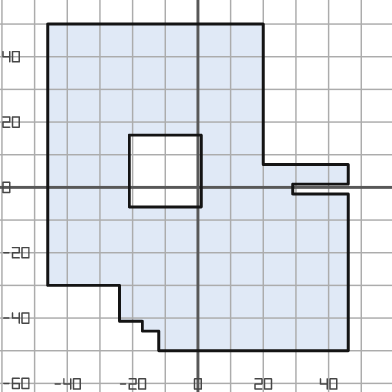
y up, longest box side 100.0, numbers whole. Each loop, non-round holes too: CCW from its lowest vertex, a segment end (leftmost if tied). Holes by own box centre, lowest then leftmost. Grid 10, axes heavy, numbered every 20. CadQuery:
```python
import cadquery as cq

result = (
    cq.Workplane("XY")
    .moveTo(-12.0, -50.0)
    .lineTo(46.0, -50.0)
    .lineTo(46.0, -2.0)
    .lineTo(29.0, -2.0)
    .lineTo(29.0, 1.0)
    .lineTo(46.0, 1.0)
    .lineTo(46.0, 7.0)
    .lineTo(20.0, 7.0)
    .lineTo(20.0, 50.0)
    .lineTo(-46.0, 50.0)
    .lineTo(-46.0, -30.0)
    .lineTo(-24.0, -30.0)
    .lineTo(-24.0, -41.0)
    .lineTo(-17.0, -41.0)
    .lineTo(-17.0, -44.0)
    .lineTo(-12.0, -44.0)
    .close()
    .moveTo(-21.0, -6.0)
    .lineTo(1.0, -6.0)
    .lineTo(1.0, 16.0)
    .lineTo(-21.0, 16.0)
    .close()
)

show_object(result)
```